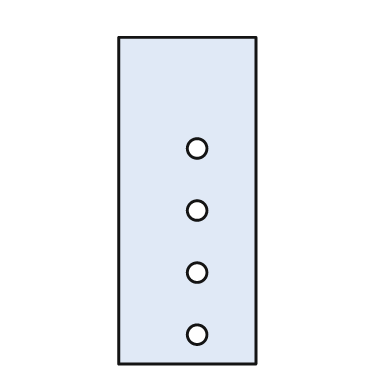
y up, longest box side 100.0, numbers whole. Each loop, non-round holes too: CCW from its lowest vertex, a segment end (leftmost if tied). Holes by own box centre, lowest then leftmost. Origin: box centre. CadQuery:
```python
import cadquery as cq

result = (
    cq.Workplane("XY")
    .moveTo(-21.0, -50.0)
    .lineTo(21.0, -50.0)
    .lineTo(21.0, 50.0)
    .lineTo(-21.0, 50.0)
    .close()
    .moveTo(3.0, -41.0)
    .circle(3.0)
    .moveTo(3.0, -22.0)
    .circle(3.0)
    .moveTo(3.0, -3.0)
    .circle(3.0)
    .moveTo(3.0, 16.0)
    .circle(3.0)
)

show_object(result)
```